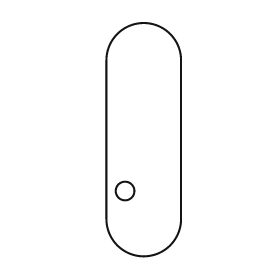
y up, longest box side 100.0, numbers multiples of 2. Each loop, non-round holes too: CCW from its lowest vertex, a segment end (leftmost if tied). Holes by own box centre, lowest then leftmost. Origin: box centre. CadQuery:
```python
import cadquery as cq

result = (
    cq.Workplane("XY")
    .moveTo(-16.0, -34.0)
    .threePointArc((0.0, -50.0), (16.0, -34.0))
    .lineTo(16.0, 34.0)
    .threePointArc((0.0, 50.0), (-16.0, 34.0))
    .close()
    .moveTo(-8.0, -22.0)
    .circle(4.0)
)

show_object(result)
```